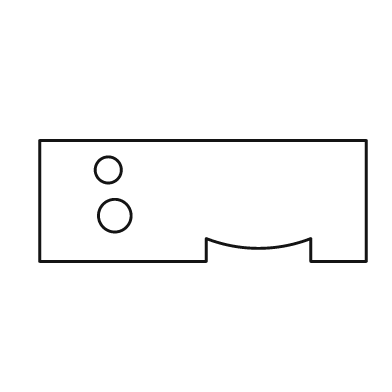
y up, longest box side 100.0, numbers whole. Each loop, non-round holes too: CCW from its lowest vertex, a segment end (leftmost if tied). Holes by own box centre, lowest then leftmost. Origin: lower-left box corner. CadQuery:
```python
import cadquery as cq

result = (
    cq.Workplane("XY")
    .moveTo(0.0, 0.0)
    .lineTo(51.0, 0.0)
    .lineTo(51.0, 7.0)
    .threePointArc((67.0, 4.0), (83.0, 7.0))
    .lineTo(83.0, 0.0)
    .lineTo(100.0, 0.0)
    .lineTo(100.0, 37.0)
    .lineTo(0.0, 37.0)
    .close()
    .moveTo(23.0, 14.0)
    .circle(5.0)
    .moveTo(21.0, 28.0)
    .circle(4.0)
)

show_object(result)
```